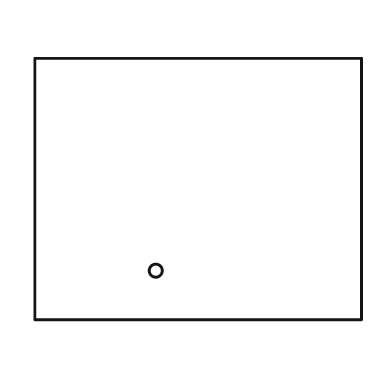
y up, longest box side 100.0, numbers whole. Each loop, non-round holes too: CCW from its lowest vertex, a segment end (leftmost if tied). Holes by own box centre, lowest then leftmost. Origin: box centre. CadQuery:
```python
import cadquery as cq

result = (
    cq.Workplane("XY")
    .moveTo(-50.0, -40.0)
    .lineTo(50.0, -40.0)
    .lineTo(50.0, 40.0)
    .lineTo(-50.0, 40.0)
    .close()
    .moveTo(-13.0, -25.0)
    .circle(2.0)
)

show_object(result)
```